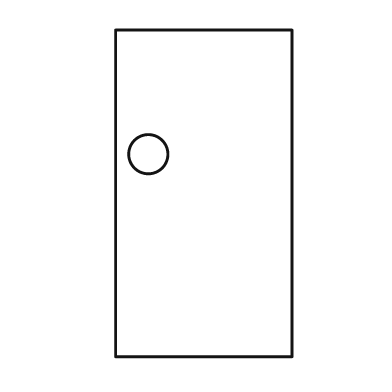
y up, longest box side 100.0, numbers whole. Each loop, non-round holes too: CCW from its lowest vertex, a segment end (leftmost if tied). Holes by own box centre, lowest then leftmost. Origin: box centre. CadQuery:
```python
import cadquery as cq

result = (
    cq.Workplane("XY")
    .moveTo(-27.0, -50.0)
    .lineTo(27.0, -50.0)
    .lineTo(27.0, 50.0)
    .lineTo(-27.0, 50.0)
    .close()
    .moveTo(-17.0, 12.0)
    .circle(6.0)
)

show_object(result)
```